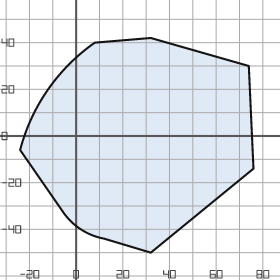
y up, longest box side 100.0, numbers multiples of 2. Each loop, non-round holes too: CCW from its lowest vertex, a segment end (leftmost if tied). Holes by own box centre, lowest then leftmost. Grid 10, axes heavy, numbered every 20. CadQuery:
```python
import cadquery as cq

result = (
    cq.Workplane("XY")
    .moveTo(32.0, -50.0)
    .lineTo(76.0, -14.0)
    .lineTo(74.0, 30.0)
    .lineTo(32.0, 42.0)
    .lineTo(8.0, 40.0)
    .threePointArc((-12.0, 20.0), (-24.0, -6.0))
    .lineTo(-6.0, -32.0)
    .threePointArc((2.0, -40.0), (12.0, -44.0))
    .close()
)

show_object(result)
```